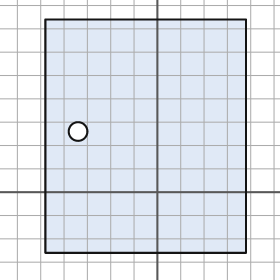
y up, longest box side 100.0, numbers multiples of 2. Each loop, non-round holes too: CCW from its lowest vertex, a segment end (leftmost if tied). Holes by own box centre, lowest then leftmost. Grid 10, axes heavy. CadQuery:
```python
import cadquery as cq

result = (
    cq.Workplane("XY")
    .moveTo(-48.0, -26.0)
    .lineTo(38.0, -26.0)
    .lineTo(38.0, 74.0)
    .lineTo(-48.0, 74.0)
    .close()
    .moveTo(-34.0, 26.0)
    .circle(4.0)
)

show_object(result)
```